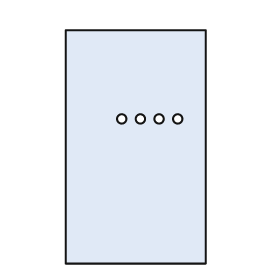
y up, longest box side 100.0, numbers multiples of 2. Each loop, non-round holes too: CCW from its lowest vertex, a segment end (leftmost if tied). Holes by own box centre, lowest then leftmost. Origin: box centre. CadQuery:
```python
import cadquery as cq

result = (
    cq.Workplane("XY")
    .moveTo(-30.0, -50.0)
    .lineTo(30.0, -50.0)
    .lineTo(30.0, 50.0)
    .lineTo(-30.0, 50.0)
    .close()
    .moveTo(-6.0, 12.0)
    .circle(2.0)
    .moveTo(2.0, 12.0)
    .circle(2.0)
    .moveTo(10.0, 12.0)
    .circle(2.0)
    .moveTo(18.0, 12.0)
    .circle(2.0)
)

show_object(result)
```